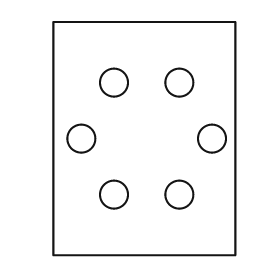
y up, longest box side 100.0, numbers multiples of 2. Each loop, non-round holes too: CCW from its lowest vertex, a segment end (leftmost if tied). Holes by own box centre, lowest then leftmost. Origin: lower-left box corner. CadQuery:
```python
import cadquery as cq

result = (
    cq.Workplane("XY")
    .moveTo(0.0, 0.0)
    .lineTo(78.0, 0.0)
    .lineTo(78.0, 100.0)
    .lineTo(0.0, 100.0)
    .close()
    .moveTo(26.0, 26.0)
    .circle(6.0)
    .moveTo(54.0, 26.0)
    .circle(6.0)
    .moveTo(12.0, 50.0)
    .circle(6.0)
    .moveTo(68.0, 50.0)
    .circle(6.0)
    .moveTo(26.0, 74.0)
    .circle(6.0)
    .moveTo(54.0, 74.0)
    .circle(6.0)
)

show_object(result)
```